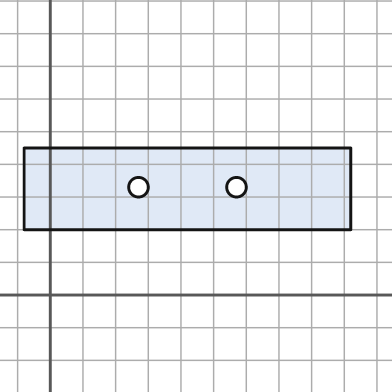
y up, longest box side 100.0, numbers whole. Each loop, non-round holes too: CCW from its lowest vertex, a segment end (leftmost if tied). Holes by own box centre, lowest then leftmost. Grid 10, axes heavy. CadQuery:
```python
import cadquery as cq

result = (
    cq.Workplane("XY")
    .moveTo(-8.0, 20.0)
    .lineTo(92.0, 20.0)
    .lineTo(92.0, 45.0)
    .lineTo(-8.0, 45.0)
    .close()
    .moveTo(27.0, 33.0)
    .circle(3.0)
    .moveTo(57.0, 33.0)
    .circle(3.0)
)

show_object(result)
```